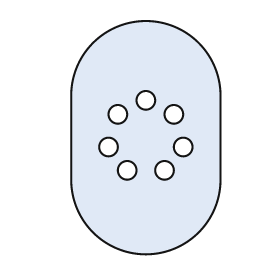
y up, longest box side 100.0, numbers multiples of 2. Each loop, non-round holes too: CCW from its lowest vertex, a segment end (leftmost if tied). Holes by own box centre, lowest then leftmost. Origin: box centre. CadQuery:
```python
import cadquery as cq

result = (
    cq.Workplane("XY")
    .moveTo(-32.0, -18.0)
    .threePointArc((0.0, -50.0), (32.0, -18.0))
    .lineTo(32.0, 18.0)
    .threePointArc((0.0, 50.0), (-32.0, 18.0))
    .close()
    .moveTo(-8.0, -14.0)
    .circle(4.0)
    .moveTo(8.0, -14.0)
    .circle(4.0)
    .moveTo(-16.0, -4.0)
    .circle(4.0)
    .moveTo(16.0, -4.0)
    .circle(4.0)
    .moveTo(-12.0, 10.0)
    .circle(4.0)
    .moveTo(12.0, 10.0)
    .circle(4.0)
    .moveTo(0.0, 16.0)
    .circle(4.0)
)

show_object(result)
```